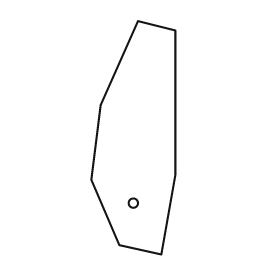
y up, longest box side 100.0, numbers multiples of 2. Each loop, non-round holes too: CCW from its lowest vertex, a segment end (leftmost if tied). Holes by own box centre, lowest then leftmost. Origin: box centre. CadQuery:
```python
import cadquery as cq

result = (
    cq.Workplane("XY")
    .moveTo(12.0, -50.0)
    .lineTo(18.0, -16.0)
    .lineTo(18.0, 46.0)
    .lineTo(2.0, 50.0)
    .lineTo(-14.0, 14.0)
    .lineTo(-18.0, -18.0)
    .lineTo(-6.0, -46.0)
    .close()
    .moveTo(0.0, -28.0)
    .circle(2.0)
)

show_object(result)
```